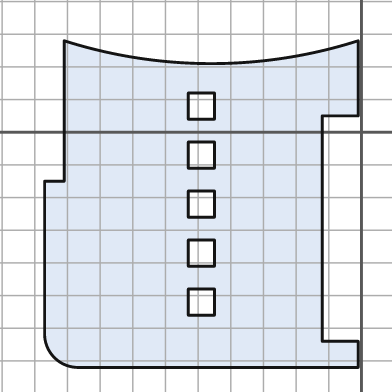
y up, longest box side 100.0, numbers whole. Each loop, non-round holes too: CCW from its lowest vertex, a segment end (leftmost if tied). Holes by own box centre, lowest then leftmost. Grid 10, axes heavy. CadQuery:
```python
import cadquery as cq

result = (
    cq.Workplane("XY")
    .moveTo(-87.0, -72.0)
    .lineTo(-1.0, -72.0)
    .lineTo(-1.0, -64.0)
    .lineTo(-12.0, -64.0)
    .lineTo(-12.0, 5.0)
    .lineTo(-1.0, 5.0)
    .lineTo(-1.0, 28.0)
    .threePointArc((-46.0, 21.0), (-91.0, 28.0))
    .lineTo(-91.0, -15.0)
    .lineTo(-97.0, -15.0)
    .lineTo(-97.0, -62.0)
    .threePointArc((-94.0, -69.0), (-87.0, -72.0))
    .close()
    .moveTo(-53.0, -56.0)
    .lineTo(-45.0, -56.0)
    .lineTo(-45.0, -48.0)
    .lineTo(-53.0, -48.0)
    .close()
    .moveTo(-53.0, -41.0)
    .lineTo(-45.0, -41.0)
    .lineTo(-45.0, -33.0)
    .lineTo(-53.0, -33.0)
    .close()
    .moveTo(-53.0, -26.0)
    .lineTo(-45.0, -26.0)
    .lineTo(-45.0, -18.0)
    .lineTo(-53.0, -18.0)
    .close()
    .moveTo(-53.0, -11.0)
    .lineTo(-45.0, -11.0)
    .lineTo(-45.0, -3.0)
    .lineTo(-53.0, -3.0)
    .close()
    .moveTo(-53.0, 4.0)
    .lineTo(-45.0, 4.0)
    .lineTo(-45.0, 12.0)
    .lineTo(-53.0, 12.0)
    .close()
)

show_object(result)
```